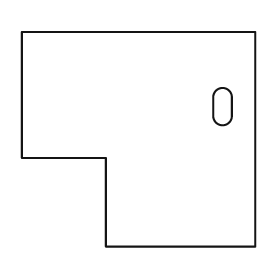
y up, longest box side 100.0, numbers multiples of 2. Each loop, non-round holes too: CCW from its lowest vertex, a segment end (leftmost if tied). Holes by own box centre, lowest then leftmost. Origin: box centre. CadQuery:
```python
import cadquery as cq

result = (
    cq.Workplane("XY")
    .moveTo(-14.0, -46.0)
    .lineTo(50.0, -46.0)
    .lineTo(50.0, 46.0)
    .lineTo(-50.0, 46.0)
    .lineTo(-50.0, -8.0)
    .lineTo(-14.0, -8.0)
    .close()
    .moveTo(32.0, 10.0)
    .threePointArc((36.0, 6.0), (40.0, 10.0))
    .lineTo(40.0, 18.0)
    .threePointArc((36.0, 22.0), (32.0, 18.0))
    .close()
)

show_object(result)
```